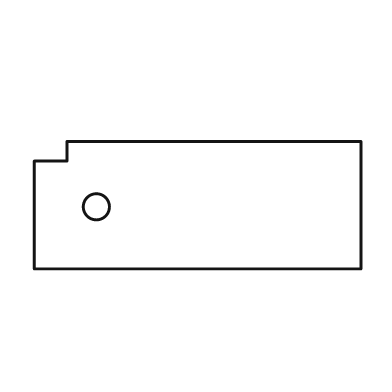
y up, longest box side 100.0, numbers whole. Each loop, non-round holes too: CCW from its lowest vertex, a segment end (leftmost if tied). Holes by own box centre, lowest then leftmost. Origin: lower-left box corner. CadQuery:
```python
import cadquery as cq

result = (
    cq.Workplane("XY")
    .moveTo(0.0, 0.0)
    .lineTo(100.0, 0.0)
    .lineTo(100.0, 39.0)
    .lineTo(10.0, 39.0)
    .lineTo(10.0, 33.0)
    .lineTo(0.0, 33.0)
    .close()
    .moveTo(19.0, 19.0)
    .circle(4.0)
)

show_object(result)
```